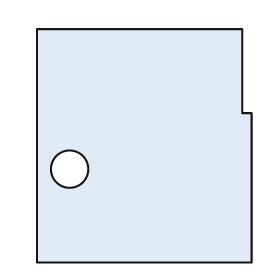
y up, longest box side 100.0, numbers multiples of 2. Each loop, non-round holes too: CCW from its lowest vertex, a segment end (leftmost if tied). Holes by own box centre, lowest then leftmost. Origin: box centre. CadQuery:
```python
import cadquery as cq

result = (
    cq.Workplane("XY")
    .moveTo(-46.0, -50.0)
    .lineTo(46.0, -50.0)
    .lineTo(46.0, 14.0)
    .lineTo(42.0, 14.0)
    .lineTo(42.0, 50.0)
    .lineTo(-46.0, 50.0)
    .close()
    .moveTo(-32.0, -10.0)
    .circle(8.0)
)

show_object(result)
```